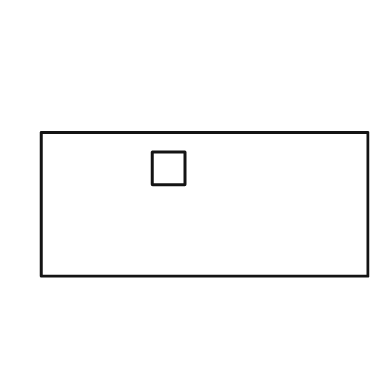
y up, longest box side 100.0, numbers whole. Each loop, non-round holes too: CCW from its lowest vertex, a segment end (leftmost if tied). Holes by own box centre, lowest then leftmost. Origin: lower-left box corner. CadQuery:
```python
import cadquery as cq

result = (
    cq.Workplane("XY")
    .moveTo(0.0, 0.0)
    .lineTo(100.0, 0.0)
    .lineTo(100.0, 44.0)
    .lineTo(0.0, 44.0)
    .close()
    .moveTo(34.0, 28.0)
    .lineTo(44.0, 28.0)
    .lineTo(44.0, 38.0)
    .lineTo(34.0, 38.0)
    .close()
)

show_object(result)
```